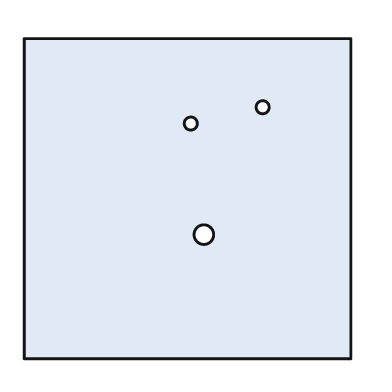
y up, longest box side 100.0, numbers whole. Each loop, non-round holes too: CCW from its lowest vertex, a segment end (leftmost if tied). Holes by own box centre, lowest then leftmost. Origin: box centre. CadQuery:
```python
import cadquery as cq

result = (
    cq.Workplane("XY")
    .moveTo(-50.0, -49.0)
    .lineTo(50.0, -49.0)
    .lineTo(50.0, 49.0)
    .lineTo(-50.0, 49.0)
    .close()
    .moveTo(5.0, -11.0)
    .circle(3.0)
    .moveTo(1.0, 23.0)
    .circle(2.0)
    .moveTo(23.0, 28.0)
    .circle(2.0)
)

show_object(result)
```